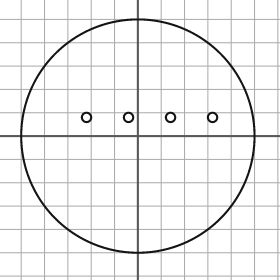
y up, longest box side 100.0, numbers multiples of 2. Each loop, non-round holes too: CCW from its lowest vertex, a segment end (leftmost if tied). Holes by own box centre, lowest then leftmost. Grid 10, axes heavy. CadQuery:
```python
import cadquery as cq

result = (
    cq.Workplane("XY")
    .moveTo(0.0, 0.0)
    .circle(50.0)
    .moveTo(-22.0, 8.0)
    .circle(2.0)
    .moveTo(-4.0, 8.0)
    .circle(2.0)
    .moveTo(14.0, 8.0)
    .circle(2.0)
    .moveTo(32.0, 8.0)
    .circle(2.0)
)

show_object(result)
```